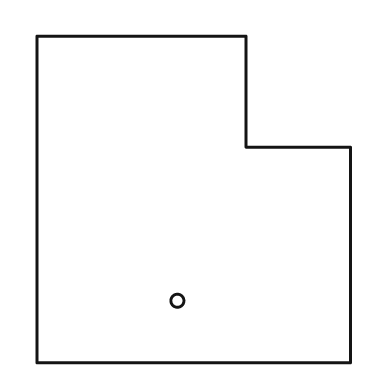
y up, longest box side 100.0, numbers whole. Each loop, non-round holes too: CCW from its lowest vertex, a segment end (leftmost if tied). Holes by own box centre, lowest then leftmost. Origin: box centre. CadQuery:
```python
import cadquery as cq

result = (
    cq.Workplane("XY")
    .moveTo(-48.0, -50.0)
    .lineTo(48.0, -50.0)
    .lineTo(48.0, 16.0)
    .lineTo(16.0, 16.0)
    .lineTo(16.0, 50.0)
    .lineTo(-48.0, 50.0)
    .close()
    .moveTo(-5.0, -31.0)
    .circle(2.0)
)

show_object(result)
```